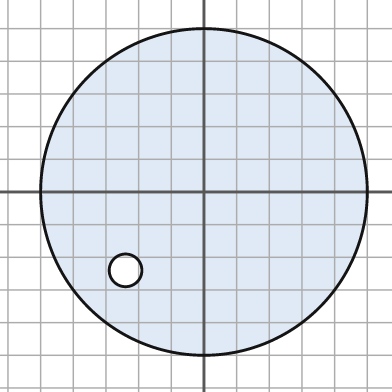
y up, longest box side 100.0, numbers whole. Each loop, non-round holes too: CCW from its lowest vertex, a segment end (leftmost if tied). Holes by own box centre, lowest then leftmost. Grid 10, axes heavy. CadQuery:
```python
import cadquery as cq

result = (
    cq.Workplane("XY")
    .moveTo(0.0, 0.0)
    .circle(50.0)
    .moveTo(-24.0, -24.0)
    .circle(5.0)
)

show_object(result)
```